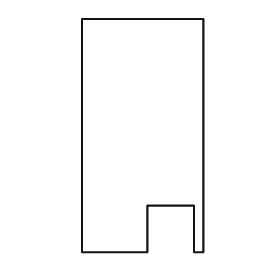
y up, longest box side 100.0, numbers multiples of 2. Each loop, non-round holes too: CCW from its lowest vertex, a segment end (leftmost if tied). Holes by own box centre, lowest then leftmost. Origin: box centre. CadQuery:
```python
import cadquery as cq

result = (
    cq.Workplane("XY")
    .moveTo(-26.0, -50.0)
    .lineTo(2.0, -50.0)
    .lineTo(2.0, -30.0)
    .lineTo(22.0, -30.0)
    .lineTo(22.0, -50.0)
    .lineTo(26.0, -50.0)
    .lineTo(26.0, 50.0)
    .lineTo(-26.0, 50.0)
    .close()
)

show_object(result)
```